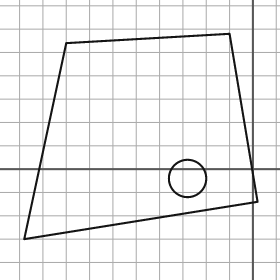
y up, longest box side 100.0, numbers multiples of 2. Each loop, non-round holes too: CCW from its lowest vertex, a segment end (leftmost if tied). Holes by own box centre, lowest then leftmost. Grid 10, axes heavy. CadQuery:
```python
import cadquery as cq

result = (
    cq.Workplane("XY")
    .moveTo(-98.0, -30.0)
    .lineTo(2.0, -14.0)
    .lineTo(-10.0, 58.0)
    .lineTo(-80.0, 54.0)
    .close()
    .moveTo(-28.0, -4.0)
    .circle(8.0)
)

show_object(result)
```